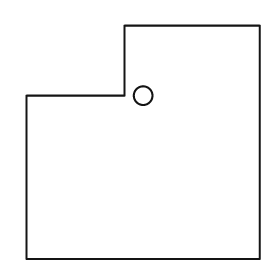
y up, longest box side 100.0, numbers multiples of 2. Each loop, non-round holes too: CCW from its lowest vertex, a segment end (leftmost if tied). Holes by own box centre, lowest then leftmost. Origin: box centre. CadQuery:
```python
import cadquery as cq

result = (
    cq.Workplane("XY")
    .moveTo(-50.0, -50.0)
    .lineTo(50.0, -50.0)
    .lineTo(50.0, 50.0)
    .lineTo(-8.0, 50.0)
    .lineTo(-8.0, 20.0)
    .lineTo(-50.0, 20.0)
    .close()
    .moveTo(0.0, 20.0)
    .circle(4.0)
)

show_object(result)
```